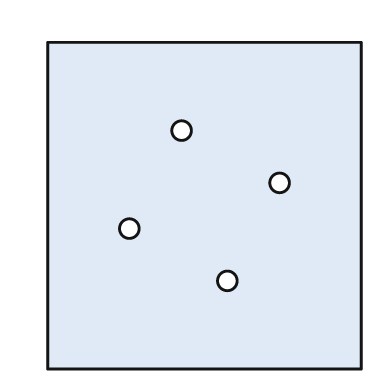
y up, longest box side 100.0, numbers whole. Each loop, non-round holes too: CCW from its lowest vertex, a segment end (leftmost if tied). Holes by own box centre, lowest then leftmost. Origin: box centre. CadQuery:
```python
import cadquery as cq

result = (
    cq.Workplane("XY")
    .moveTo(-48.0, -50.0)
    .lineTo(48.0, -50.0)
    .lineTo(48.0, 50.0)
    .lineTo(-48.0, 50.0)
    .close()
    .moveTo(7.0, -23.0)
    .circle(3.0)
    .moveTo(-23.0, -7.0)
    .circle(3.0)
    .moveTo(23.0, 7.0)
    .circle(3.0)
    .moveTo(-7.0, 23.0)
    .circle(3.0)
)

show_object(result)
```